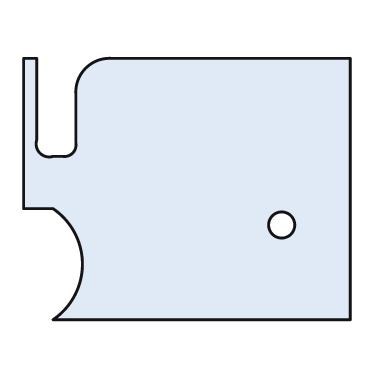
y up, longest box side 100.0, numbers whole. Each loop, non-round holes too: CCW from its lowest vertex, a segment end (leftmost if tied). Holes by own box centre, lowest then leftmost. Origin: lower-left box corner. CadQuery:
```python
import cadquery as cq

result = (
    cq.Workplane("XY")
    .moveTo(9.0, 0.0)
    .lineTo(100.0, 0.0)
    .lineTo(100.0, 80.0)
    .lineTo(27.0, 80.0)
    .threePointArc((19.0, 77.0), (16.0, 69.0))
    .lineTo(16.0, 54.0)
    .threePointArc((15.0, 51.0), (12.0, 50.0))
    .lineTo(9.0, 50.0)
    .threePointArc((5.0, 51.0), (4.0, 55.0))
    .lineTo(4.0, 80.0)
    .lineTo(0.0, 80.0)
    .lineTo(0.0, 34.0)
    .lineTo(9.0, 34.0)
    .threePointArc((18.0, 17.0), (9.0, 0.0))
    .close()
    .moveTo(79.0, 29.0)
    .circle(4.0)
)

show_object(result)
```